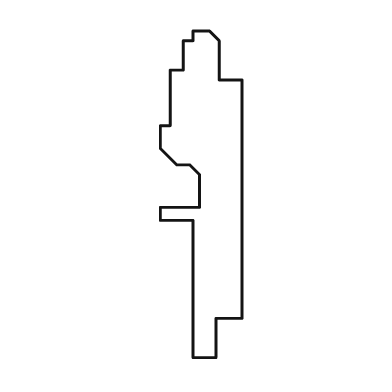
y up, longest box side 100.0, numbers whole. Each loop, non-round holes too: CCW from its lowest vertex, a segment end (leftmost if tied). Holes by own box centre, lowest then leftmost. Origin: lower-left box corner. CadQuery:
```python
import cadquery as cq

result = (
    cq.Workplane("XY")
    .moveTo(10.0, 0.0)
    .lineTo(17.0, 0.0)
    .lineTo(17.0, 12.0)
    .lineTo(25.0, 12.0)
    .lineTo(25.0, 85.0)
    .lineTo(18.0, 85.0)
    .lineTo(18.0, 97.0)
    .lineTo(15.0, 100.0)
    .lineTo(10.0, 100.0)
    .lineTo(10.0, 97.0)
    .lineTo(7.0, 97.0)
    .lineTo(7.0, 88.0)
    .lineTo(3.0, 88.0)
    .lineTo(3.0, 71.0)
    .lineTo(0.0, 71.0)
    .lineTo(0.0, 64.0)
    .lineTo(5.0, 59.0)
    .lineTo(9.0, 59.0)
    .lineTo(12.0, 56.0)
    .lineTo(12.0, 46.0)
    .lineTo(0.0, 46.0)
    .lineTo(0.0, 42.0)
    .lineTo(10.0, 42.0)
    .close()
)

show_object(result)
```